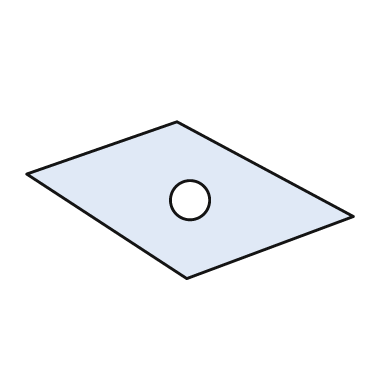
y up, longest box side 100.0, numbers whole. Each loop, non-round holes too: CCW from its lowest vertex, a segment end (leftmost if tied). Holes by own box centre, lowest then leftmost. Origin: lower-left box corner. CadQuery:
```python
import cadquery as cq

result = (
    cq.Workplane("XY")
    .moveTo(49.0, 0.0)
    .lineTo(100.0, 19.0)
    .lineTo(46.0, 48.0)
    .lineTo(0.0, 32.0)
    .close()
    .moveTo(50.0, 24.0)
    .circle(6.0)
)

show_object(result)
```